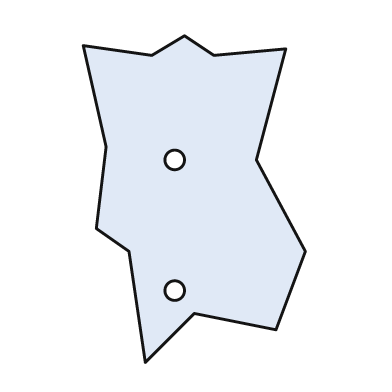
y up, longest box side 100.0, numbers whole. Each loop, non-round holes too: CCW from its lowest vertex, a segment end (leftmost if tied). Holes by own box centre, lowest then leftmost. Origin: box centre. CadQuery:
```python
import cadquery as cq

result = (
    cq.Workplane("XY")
    .moveTo(-15.0, -50.0)
    .lineTo(0.0, -35.0)
    .lineTo(25.0, -40.0)
    .lineTo(34.0, -16.0)
    .lineTo(19.0, 12.0)
    .lineTo(28.0, 46.0)
    .lineTo(6.0, 44.0)
    .lineTo(-3.0, 50.0)
    .lineTo(-13.0, 44.0)
    .lineTo(-34.0, 47.0)
    .lineTo(-27.0, 16.0)
    .lineTo(-30.0, -9.0)
    .lineTo(-20.0, -16.0)
    .close()
    .moveTo(-6.0, -28.0)
    .circle(3.0)
    .moveTo(-6.0, 12.0)
    .circle(3.0)
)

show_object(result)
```